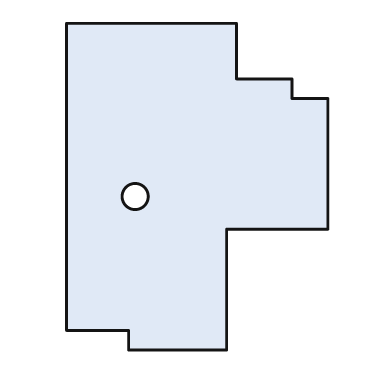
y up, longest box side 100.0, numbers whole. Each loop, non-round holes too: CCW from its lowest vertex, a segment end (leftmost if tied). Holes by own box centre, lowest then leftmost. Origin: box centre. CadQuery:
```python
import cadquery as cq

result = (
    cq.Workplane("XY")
    .moveTo(-21.0, -50.0)
    .lineTo(9.0, -50.0)
    .lineTo(9.0, -13.0)
    .lineTo(40.0, -13.0)
    .lineTo(40.0, 27.0)
    .lineTo(29.0, 27.0)
    .lineTo(29.0, 33.0)
    .lineTo(12.0, 33.0)
    .lineTo(12.0, 50.0)
    .lineTo(-40.0, 50.0)
    .lineTo(-40.0, -44.0)
    .lineTo(-21.0, -44.0)
    .close()
    .moveTo(-19.0, -3.0)
    .circle(4.0)
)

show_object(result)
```